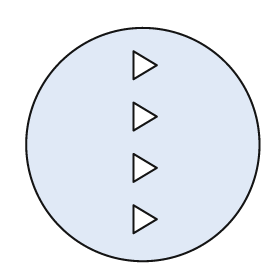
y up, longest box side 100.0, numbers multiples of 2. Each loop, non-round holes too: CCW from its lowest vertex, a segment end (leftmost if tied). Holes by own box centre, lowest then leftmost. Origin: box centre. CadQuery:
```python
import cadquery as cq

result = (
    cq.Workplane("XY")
    .moveTo(0.0, 0.0)
    .circle(50.0)
    .moveTo(-4.0, -38.0)
    .lineTo(6.0, -32.0)
    .lineTo(-4.0, -26.0)
    .close()
    .moveTo(-4.0, -16.0)
    .lineTo(6.0, -10.0)
    .lineTo(-4.0, -4.0)
    .close()
    .moveTo(-4.0, 6.0)
    .lineTo(6.0, 12.0)
    .lineTo(-4.0, 18.0)
    .close()
    .moveTo(-4.0, 28.0)
    .lineTo(6.0, 34.0)
    .lineTo(-4.0, 40.0)
    .close()
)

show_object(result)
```